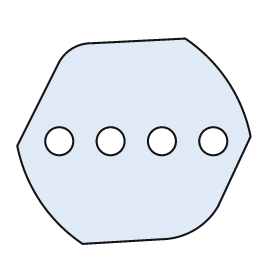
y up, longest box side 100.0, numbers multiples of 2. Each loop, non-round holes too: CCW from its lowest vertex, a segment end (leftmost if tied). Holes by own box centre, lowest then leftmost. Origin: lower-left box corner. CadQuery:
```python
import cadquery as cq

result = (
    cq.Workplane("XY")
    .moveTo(28.0, 0.0)
    .lineTo(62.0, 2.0)
    .threePointArc((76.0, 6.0), (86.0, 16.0))
    .lineTo(100.0, 46.0)
    .threePointArc((90.0, 70.0), (72.0, 88.0))
    .lineTo(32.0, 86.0)
    .threePointArc((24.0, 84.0), (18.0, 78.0))
    .lineTo(0.0, 42.0)
    .threePointArc((10.0, 18.0), (28.0, 0.0))
    .close()
    .moveTo(18.0, 44.0)
    .circle(6.0)
    .moveTo(40.0, 44.0)
    .circle(6.0)
    .moveTo(62.0, 44.0)
    .circle(6.0)
    .moveTo(84.0, 44.0)
    .circle(6.0)
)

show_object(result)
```